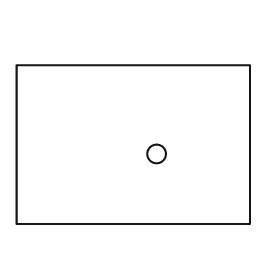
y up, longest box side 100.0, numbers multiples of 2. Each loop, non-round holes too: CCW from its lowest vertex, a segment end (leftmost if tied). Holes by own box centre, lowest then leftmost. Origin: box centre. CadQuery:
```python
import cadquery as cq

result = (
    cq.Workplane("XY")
    .moveTo(-50.0, -34.0)
    .lineTo(50.0, -34.0)
    .lineTo(50.0, 34.0)
    .lineTo(-50.0, 34.0)
    .close()
    .moveTo(10.0, -4.0)
    .circle(4.0)
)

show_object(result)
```